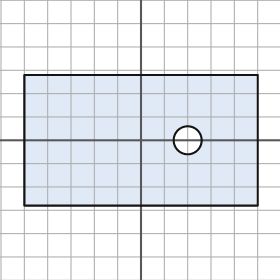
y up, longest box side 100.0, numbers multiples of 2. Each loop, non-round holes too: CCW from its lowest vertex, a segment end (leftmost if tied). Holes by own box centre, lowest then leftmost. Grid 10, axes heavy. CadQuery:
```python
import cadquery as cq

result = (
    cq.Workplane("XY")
    .moveTo(-50.0, -28.0)
    .lineTo(50.0, -28.0)
    .lineTo(50.0, 28.0)
    .lineTo(-50.0, 28.0)
    .close()
    .moveTo(20.0, 0.0)
    .circle(6.0)
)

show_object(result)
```